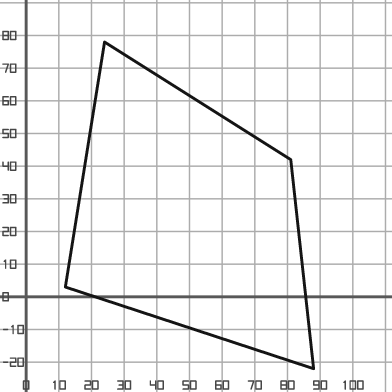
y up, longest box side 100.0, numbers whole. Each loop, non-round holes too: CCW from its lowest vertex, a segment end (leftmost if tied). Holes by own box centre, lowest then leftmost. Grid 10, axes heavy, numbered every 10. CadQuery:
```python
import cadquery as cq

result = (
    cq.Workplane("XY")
    .moveTo(88.0, -22.0)
    .lineTo(81.0, 42.0)
    .lineTo(24.0, 78.0)
    .lineTo(12.0, 3.0)
    .close()
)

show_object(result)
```